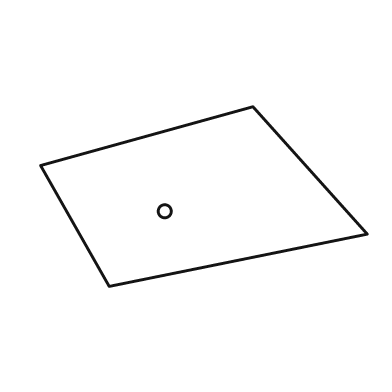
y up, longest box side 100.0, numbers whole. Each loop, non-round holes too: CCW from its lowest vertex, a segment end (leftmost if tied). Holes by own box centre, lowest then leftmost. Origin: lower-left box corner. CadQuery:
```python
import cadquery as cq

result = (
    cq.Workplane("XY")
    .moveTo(21.0, 0.0)
    .lineTo(100.0, 16.0)
    .lineTo(65.0, 55.0)
    .lineTo(0.0, 37.0)
    .close()
    .moveTo(38.0, 23.0)
    .circle(2.0)
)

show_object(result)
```